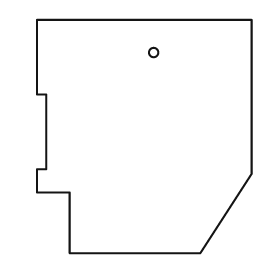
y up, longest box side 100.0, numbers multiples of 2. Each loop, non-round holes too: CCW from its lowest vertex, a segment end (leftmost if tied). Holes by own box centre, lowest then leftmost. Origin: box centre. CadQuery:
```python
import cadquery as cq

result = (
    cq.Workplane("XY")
    .moveTo(-32.0, -50.0)
    .lineTo(24.0, -50.0)
    .lineTo(46.0, -16.0)
    .lineTo(46.0, 50.0)
    .lineTo(-46.0, 50.0)
    .lineTo(-46.0, 18.0)
    .lineTo(-42.0, 18.0)
    .lineTo(-42.0, -14.0)
    .lineTo(-46.0, -14.0)
    .lineTo(-46.0, -24.0)
    .lineTo(-32.0, -24.0)
    .close()
    .moveTo(4.0, 36.0)
    .circle(2.0)
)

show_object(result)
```